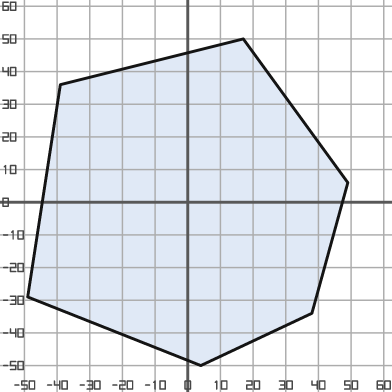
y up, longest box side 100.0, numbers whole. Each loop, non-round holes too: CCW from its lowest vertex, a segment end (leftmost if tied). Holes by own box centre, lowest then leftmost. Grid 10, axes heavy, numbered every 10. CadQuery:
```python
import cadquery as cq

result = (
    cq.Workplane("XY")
    .moveTo(4.0, -50.0)
    .lineTo(38.0, -34.0)
    .lineTo(49.0, 6.0)
    .lineTo(17.0, 50.0)
    .lineTo(-39.0, 36.0)
    .lineTo(-49.0, -29.0)
    .close()
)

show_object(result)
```